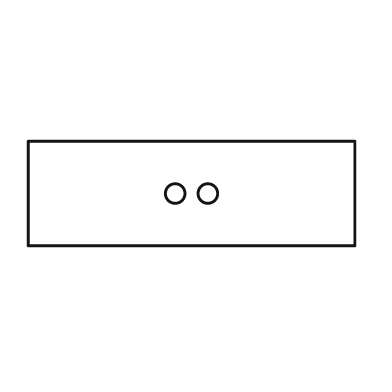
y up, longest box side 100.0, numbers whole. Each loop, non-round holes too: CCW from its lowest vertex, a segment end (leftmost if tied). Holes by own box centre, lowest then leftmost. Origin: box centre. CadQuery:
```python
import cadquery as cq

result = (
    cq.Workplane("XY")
    .moveTo(-50.0, -16.0)
    .lineTo(50.0, -16.0)
    .lineTo(50.0, 16.0)
    .lineTo(-50.0, 16.0)
    .close()
    .moveTo(-5.0, 0.0)
    .circle(3.0)
    .moveTo(5.0, 0.0)
    .circle(3.0)
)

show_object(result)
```